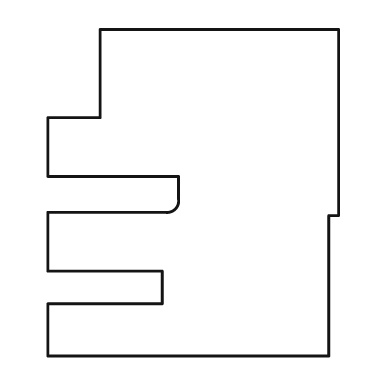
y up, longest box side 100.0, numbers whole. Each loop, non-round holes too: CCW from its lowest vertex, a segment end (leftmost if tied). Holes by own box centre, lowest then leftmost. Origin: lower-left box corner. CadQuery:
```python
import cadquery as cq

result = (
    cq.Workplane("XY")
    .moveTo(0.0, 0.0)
    .lineTo(86.0, 0.0)
    .lineTo(86.0, 43.0)
    .lineTo(89.0, 43.0)
    .lineTo(89.0, 100.0)
    .lineTo(16.0, 100.0)
    .lineTo(16.0, 73.0)
    .lineTo(0.0, 73.0)
    .lineTo(0.0, 55.0)
    .lineTo(40.0, 55.0)
    .lineTo(40.0, 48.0)
    .threePointArc((39.0, 45.0), (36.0, 44.0))
    .lineTo(0.0, 44.0)
    .lineTo(0.0, 26.0)
    .lineTo(35.0, 26.0)
    .lineTo(35.0, 16.0)
    .lineTo(0.0, 16.0)
    .close()
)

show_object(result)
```